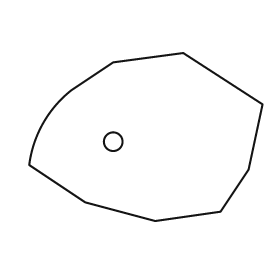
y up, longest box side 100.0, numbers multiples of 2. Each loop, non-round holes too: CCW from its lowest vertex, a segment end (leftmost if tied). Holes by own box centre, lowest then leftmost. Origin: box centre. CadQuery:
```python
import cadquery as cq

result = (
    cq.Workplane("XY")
    .moveTo(4.0, -36.0)
    .lineTo(32.0, -32.0)
    .lineTo(44.0, -14.0)
    .lineTo(50.0, 14.0)
    .lineTo(16.0, 36.0)
    .lineTo(-14.0, 32.0)
    .lineTo(-32.0, 20.0)
    .threePointArc((-44.0, 6.0), (-50.0, -12.0))
    .lineTo(-26.0, -28.0)
    .close()
    .moveTo(-14.0, -2.0)
    .circle(4.0)
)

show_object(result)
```